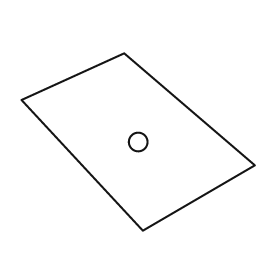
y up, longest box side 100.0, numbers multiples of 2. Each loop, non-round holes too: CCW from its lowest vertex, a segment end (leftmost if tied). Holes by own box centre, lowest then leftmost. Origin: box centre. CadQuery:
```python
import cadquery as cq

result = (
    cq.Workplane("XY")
    .moveTo(2.0, -38.0)
    .lineTo(50.0, -10.0)
    .lineTo(-6.0, 38.0)
    .lineTo(-50.0, 18.0)
    .close()
    .moveTo(0.0, 0.0)
    .circle(4.0)
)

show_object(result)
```